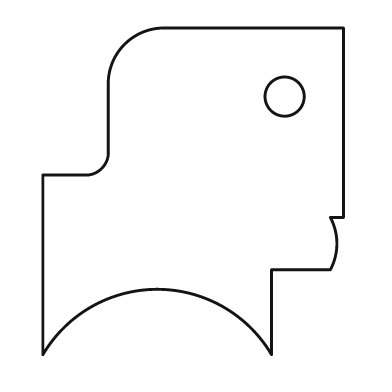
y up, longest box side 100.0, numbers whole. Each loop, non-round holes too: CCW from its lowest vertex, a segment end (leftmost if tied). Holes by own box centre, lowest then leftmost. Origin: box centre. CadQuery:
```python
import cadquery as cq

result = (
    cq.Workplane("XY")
    .moveTo(-46.0, -50.0)
    .threePointArc((-11.0, -30.0), (24.0, -50.0))
    .lineTo(24.0, -24.0)
    .lineTo(42.0, -24.0)
    .threePointArc((44.0, -16.0), (42.0, -8.0))
    .lineTo(46.0, -8.0)
    .lineTo(46.0, 50.0)
    .lineTo(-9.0, 50.0)
    .threePointArc((-21.0, 45.0), (-26.0, 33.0))
    .lineTo(-26.0, 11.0)
    .threePointArc((-28.0, 7.0), (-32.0, 5.0))
    .lineTo(-46.0, 5.0)
    .close()
    .moveTo(28.0, 29.0)
    .circle(6.0)
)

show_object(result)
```